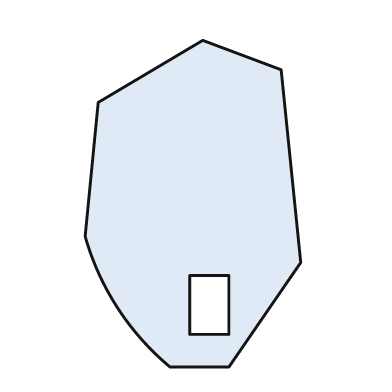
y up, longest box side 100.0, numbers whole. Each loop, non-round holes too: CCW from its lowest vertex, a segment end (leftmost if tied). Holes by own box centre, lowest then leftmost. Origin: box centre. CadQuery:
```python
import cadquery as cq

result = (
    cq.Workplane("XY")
    .moveTo(-7.0, -50.0)
    .lineTo(11.0, -50.0)
    .lineTo(33.0, -18.0)
    .lineTo(27.0, 41.0)
    .lineTo(3.0, 50.0)
    .lineTo(-29.0, 31.0)
    .lineTo(-33.0, -10.0)
    .threePointArc((-23.0, -32.0), (-7.0, -50.0))
    .close()
    .moveTo(-1.0, -40.0)
    .lineTo(11.0, -40.0)
    .lineTo(11.0, -22.0)
    .lineTo(-1.0, -22.0)
    .close()
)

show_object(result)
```